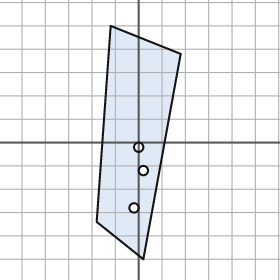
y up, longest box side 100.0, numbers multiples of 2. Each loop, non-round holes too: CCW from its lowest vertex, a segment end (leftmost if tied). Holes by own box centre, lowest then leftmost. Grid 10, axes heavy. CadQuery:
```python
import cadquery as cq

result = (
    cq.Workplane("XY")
    .moveTo(2.0, -50.0)
    .lineTo(18.0, 38.0)
    .lineTo(-12.0, 50.0)
    .lineTo(-18.0, -34.0)
    .close()
    .moveTo(-2.0, -28.0)
    .circle(2.0)
    .moveTo(2.0, -12.0)
    .circle(2.0)
    .moveTo(0.0, -2.0)
    .circle(2.0)
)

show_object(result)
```